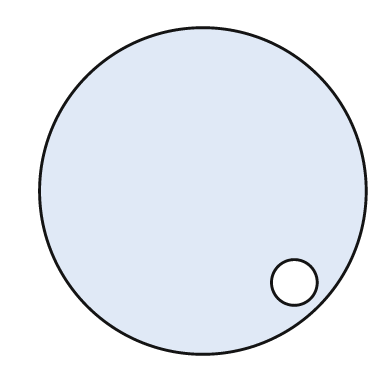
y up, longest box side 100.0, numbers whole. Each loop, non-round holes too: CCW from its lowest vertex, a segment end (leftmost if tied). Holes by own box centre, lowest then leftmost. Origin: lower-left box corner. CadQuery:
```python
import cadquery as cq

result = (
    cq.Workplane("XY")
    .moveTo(50.0, 50.0)
    .circle(50.0)
    .moveTo(78.0, 22.0)
    .circle(7.0)
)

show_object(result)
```